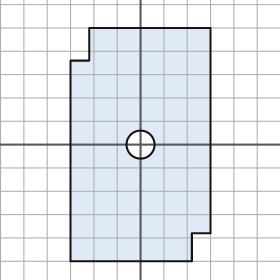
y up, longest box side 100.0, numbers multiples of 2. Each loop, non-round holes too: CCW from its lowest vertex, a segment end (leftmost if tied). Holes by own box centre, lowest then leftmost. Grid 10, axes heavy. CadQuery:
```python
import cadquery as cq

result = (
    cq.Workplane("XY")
    .moveTo(-30.0, -50.0)
    .lineTo(22.0, -50.0)
    .lineTo(22.0, -38.0)
    .lineTo(30.0, -38.0)
    .lineTo(30.0, 50.0)
    .lineTo(-22.0, 50.0)
    .lineTo(-22.0, 36.0)
    .lineTo(-30.0, 36.0)
    .close()
    .moveTo(0.0, 0.0)
    .circle(6.0)
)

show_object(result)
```